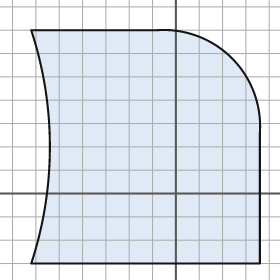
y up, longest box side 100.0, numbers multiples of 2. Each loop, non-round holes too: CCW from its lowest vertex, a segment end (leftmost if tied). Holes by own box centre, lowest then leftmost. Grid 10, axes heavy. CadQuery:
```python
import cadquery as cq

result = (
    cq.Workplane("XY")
    .moveTo(-62.0, -30.0)
    .lineTo(36.0, -30.0)
    .lineTo(36.0, 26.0)
    .threePointArc((24.0, 58.0), (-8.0, 70.0))
    .lineTo(-62.0, 70.0)
    .threePointArc((-54.0, 20.0), (-62.0, -30.0))
    .close()
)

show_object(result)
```